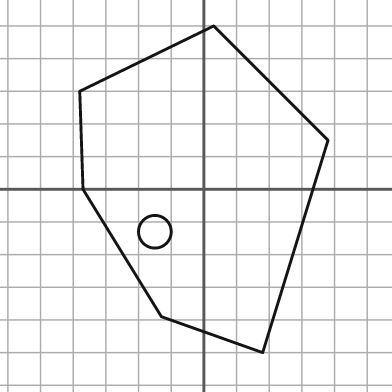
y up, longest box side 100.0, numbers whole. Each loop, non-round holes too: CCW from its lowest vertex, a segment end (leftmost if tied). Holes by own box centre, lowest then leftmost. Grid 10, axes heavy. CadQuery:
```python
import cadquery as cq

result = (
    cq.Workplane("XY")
    .moveTo(18.0, -50.0)
    .lineTo(38.0, 15.0)
    .lineTo(3.0, 50.0)
    .lineTo(-38.0, 30.0)
    .lineTo(-37.0, 0.0)
    .lineTo(-13.0, -39.0)
    .close()
    .moveTo(-15.0, -13.0)
    .circle(5.0)
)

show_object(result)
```